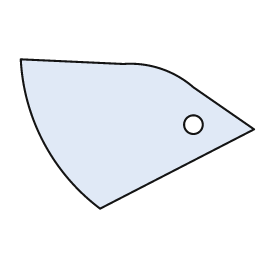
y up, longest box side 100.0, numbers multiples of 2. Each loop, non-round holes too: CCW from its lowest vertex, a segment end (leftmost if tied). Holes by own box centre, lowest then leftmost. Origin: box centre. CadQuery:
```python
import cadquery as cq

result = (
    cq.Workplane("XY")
    .moveTo(-16.0, -32.0)
    .lineTo(50.0, 2.0)
    .lineTo(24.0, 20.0)
    .threePointArc((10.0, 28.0), (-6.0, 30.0))
    .lineTo(-50.0, 32.0)
    .threePointArc((-40.0, -4.0), (-16.0, -32.0))
    .close()
    .moveTo(24.0, 4.0)
    .circle(4.0)
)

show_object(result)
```